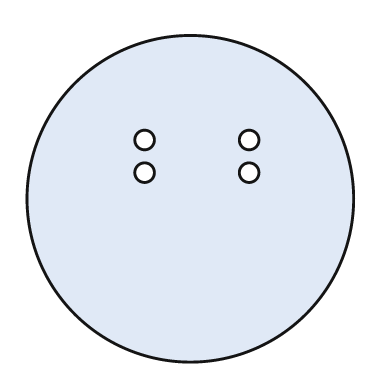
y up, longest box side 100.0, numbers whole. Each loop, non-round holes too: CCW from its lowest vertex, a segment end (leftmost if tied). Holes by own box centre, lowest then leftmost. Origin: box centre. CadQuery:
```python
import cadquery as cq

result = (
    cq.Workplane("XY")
    .moveTo(0.0, 0.0)
    .circle(50.0)
    .moveTo(-14.0, 8.0)
    .circle(3.0)
    .moveTo(18.0, 8.0)
    .circle(3.0)
    .moveTo(-14.0, 18.0)
    .circle(3.0)
    .moveTo(18.0, 18.0)
    .circle(3.0)
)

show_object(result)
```